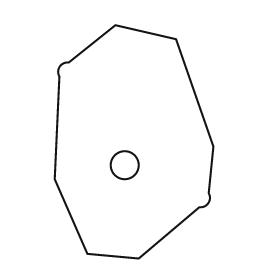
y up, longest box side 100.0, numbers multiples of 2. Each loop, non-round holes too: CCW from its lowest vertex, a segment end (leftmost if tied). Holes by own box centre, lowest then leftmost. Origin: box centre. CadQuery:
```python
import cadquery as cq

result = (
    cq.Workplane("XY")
    .moveTo(2.0, -50.0)
    .lineTo(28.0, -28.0)
    .threePointArc((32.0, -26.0), (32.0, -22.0))
    .lineTo(34.0, -2.0)
    .lineTo(18.0, 44.0)
    .lineTo(-8.0, 50.0)
    .lineTo(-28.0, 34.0)
    .threePointArc((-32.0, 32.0), (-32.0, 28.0))
    .lineTo(-34.0, -16.0)
    .lineTo(-20.0, -48.0)
    .close()
    .moveTo(-4.0, -10.0)
    .circle(6.0)
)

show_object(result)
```